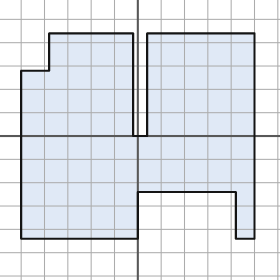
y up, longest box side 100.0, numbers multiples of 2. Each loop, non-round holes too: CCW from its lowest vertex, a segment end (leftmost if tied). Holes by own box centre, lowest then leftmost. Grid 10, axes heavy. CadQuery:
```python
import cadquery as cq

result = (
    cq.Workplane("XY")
    .moveTo(-50.0, -44.0)
    .lineTo(0.0, -44.0)
    .lineTo(0.0, -24.0)
    .lineTo(42.0, -24.0)
    .lineTo(42.0, -44.0)
    .lineTo(50.0, -44.0)
    .lineTo(50.0, 44.0)
    .lineTo(4.0, 44.0)
    .lineTo(4.0, 0.0)
    .lineTo(-2.0, 0.0)
    .lineTo(-2.0, 44.0)
    .lineTo(-38.0, 44.0)
    .lineTo(-38.0, 28.0)
    .lineTo(-50.0, 28.0)
    .close()
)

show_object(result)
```